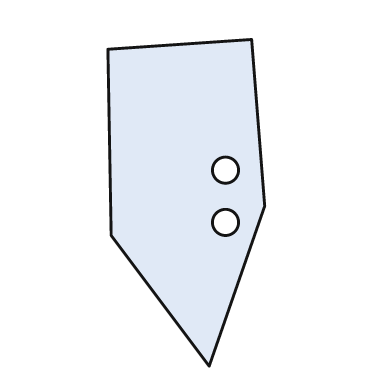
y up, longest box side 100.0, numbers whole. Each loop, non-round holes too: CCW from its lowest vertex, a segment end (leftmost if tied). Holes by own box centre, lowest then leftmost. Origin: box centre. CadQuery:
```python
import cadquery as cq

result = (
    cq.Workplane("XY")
    .moveTo(7.0, -50.0)
    .lineTo(24.0, -1.0)
    .lineTo(20.0, 50.0)
    .lineTo(-24.0, 47.0)
    .lineTo(-23.0, -10.0)
    .close()
    .moveTo(12.0, -6.0)
    .circle(4.0)
    .moveTo(12.0, 10.0)
    .circle(4.0)
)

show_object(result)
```